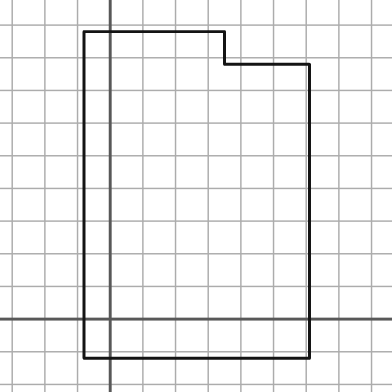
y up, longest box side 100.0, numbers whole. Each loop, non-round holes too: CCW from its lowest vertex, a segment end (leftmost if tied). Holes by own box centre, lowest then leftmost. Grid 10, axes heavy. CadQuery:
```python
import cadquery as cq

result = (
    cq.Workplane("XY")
    .moveTo(-8.0, -12.0)
    .lineTo(61.0, -12.0)
    .lineTo(61.0, 78.0)
    .lineTo(35.0, 78.0)
    .lineTo(35.0, 88.0)
    .lineTo(-8.0, 88.0)
    .close()
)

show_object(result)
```